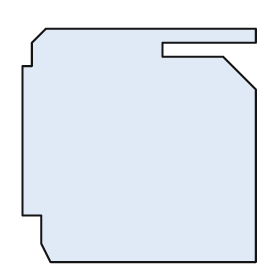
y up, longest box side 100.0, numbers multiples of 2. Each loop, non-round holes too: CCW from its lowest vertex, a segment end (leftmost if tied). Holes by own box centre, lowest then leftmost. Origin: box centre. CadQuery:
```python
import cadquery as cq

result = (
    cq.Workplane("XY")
    .moveTo(-38.0, -50.0)
    .lineTo(50.0, -50.0)
    .lineTo(50.0, 24.0)
    .lineTo(36.0, 38.0)
    .lineTo(10.0, 38.0)
    .lineTo(10.0, 44.0)
    .lineTo(50.0, 44.0)
    .lineTo(50.0, 50.0)
    .lineTo(-40.0, 50.0)
    .lineTo(-46.0, 44.0)
    .lineTo(-46.0, 34.0)
    .lineTo(-50.0, 34.0)
    .lineTo(-50.0, -30.0)
    .lineTo(-42.0, -30.0)
    .lineTo(-42.0, -42.0)
    .close()
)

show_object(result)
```